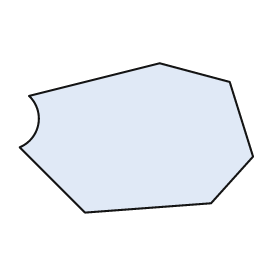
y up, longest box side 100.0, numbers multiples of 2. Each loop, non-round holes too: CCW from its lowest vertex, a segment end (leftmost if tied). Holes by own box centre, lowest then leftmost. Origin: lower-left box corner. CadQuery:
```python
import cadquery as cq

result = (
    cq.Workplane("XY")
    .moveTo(28.0, 0.0)
    .lineTo(82.0, 4.0)
    .lineTo(100.0, 24.0)
    .lineTo(90.0, 56.0)
    .lineTo(60.0, 64.0)
    .lineTo(4.0, 50.0)
    .threePointArc((8.0, 38.0), (0.0, 28.0))
    .close()
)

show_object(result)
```